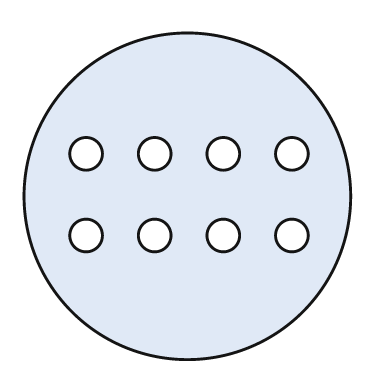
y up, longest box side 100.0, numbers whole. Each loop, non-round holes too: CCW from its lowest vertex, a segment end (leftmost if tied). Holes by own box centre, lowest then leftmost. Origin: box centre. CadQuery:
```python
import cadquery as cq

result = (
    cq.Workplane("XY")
    .moveTo(0.0, 0.0)
    .circle(50.0)
    .moveTo(-31.0, -12.0)
    .circle(5.0)
    .moveTo(-10.0, -12.0)
    .circle(5.0)
    .moveTo(11.0, -12.0)
    .circle(5.0)
    .moveTo(32.0, -12.0)
    .circle(5.0)
    .moveTo(-31.0, 13.0)
    .circle(5.0)
    .moveTo(-10.0, 13.0)
    .circle(5.0)
    .moveTo(11.0, 13.0)
    .circle(5.0)
    .moveTo(32.0, 13.0)
    .circle(5.0)
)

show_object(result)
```